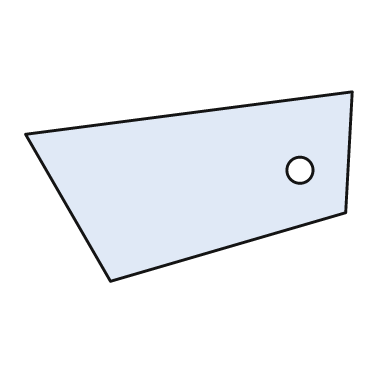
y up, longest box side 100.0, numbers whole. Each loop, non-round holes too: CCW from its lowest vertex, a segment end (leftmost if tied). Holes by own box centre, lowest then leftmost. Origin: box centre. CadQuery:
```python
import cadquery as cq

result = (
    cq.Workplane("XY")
    .moveTo(-24.0, -29.0)
    .lineTo(48.0, -8.0)
    .lineTo(50.0, 29.0)
    .lineTo(-50.0, 16.0)
    .close()
    .moveTo(34.0, 5.0)
    .circle(4.0)
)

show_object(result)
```